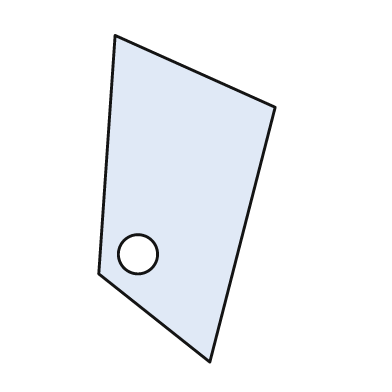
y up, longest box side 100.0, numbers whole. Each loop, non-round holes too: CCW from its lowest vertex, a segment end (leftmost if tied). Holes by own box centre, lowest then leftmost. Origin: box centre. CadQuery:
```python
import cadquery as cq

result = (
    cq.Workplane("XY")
    .moveTo(7.0, -50.0)
    .lineTo(27.0, 28.0)
    .lineTo(-22.0, 50.0)
    .lineTo(-27.0, -23.0)
    .close()
    .moveTo(-15.0, -17.0)
    .circle(6.0)
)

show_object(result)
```